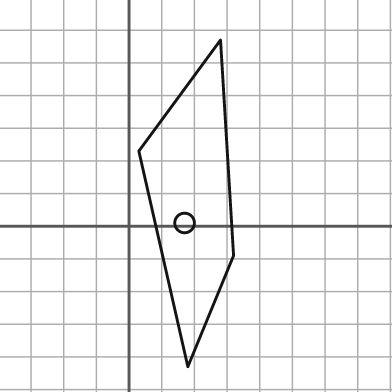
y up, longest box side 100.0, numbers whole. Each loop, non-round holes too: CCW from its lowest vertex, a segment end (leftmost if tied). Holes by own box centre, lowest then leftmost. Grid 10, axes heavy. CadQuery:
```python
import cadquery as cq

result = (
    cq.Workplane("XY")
    .moveTo(18.0, -43.0)
    .lineTo(32.0, -9.0)
    .lineTo(28.0, 57.0)
    .lineTo(3.0, 23.0)
    .close()
    .moveTo(17.0, 1.0)
    .circle(3.0)
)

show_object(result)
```